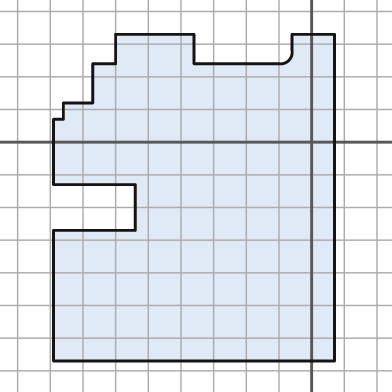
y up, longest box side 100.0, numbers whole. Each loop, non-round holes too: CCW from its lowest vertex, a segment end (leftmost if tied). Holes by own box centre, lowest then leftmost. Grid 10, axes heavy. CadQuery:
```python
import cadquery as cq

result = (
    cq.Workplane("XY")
    .moveTo(-79.0, -67.0)
    .lineTo(7.0, -67.0)
    .lineTo(7.0, 33.0)
    .lineTo(-6.0, 33.0)
    .lineTo(-6.0, 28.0)
    .threePointArc((-7.0, 25.0), (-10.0, 24.0))
    .lineTo(-36.0, 24.0)
    .lineTo(-36.0, 33.0)
    .lineTo(-60.0, 33.0)
    .lineTo(-60.0, 24.0)
    .lineTo(-67.0, 24.0)
    .lineTo(-67.0, 12.0)
    .lineTo(-76.0, 12.0)
    .lineTo(-76.0, 7.0)
    .lineTo(-79.0, 7.0)
    .lineTo(-79.0, -13.0)
    .lineTo(-54.0, -13.0)
    .lineTo(-54.0, -27.0)
    .lineTo(-79.0, -27.0)
    .close()
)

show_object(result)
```